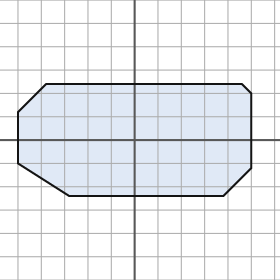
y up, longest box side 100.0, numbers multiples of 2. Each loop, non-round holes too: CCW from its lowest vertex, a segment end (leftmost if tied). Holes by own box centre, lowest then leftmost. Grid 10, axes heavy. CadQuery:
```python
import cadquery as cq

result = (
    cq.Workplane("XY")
    .moveTo(-28.0, -24.0)
    .lineTo(38.0, -24.0)
    .lineTo(50.0, -12.0)
    .lineTo(50.0, 20.0)
    .lineTo(46.0, 24.0)
    .lineTo(-38.0, 24.0)
    .lineTo(-50.0, 12.0)
    .lineTo(-50.0, -10.0)
    .close()
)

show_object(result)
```